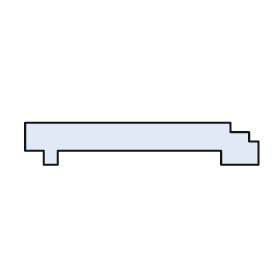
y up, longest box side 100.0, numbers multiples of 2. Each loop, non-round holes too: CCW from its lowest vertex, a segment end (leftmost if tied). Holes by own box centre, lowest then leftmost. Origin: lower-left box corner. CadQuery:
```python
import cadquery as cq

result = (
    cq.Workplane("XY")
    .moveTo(8.0, 0.0)
    .lineTo(14.0, 0.0)
    .lineTo(14.0, 6.0)
    .lineTo(84.0, 6.0)
    .lineTo(84.0, 0.0)
    .lineTo(100.0, 0.0)
    .lineTo(100.0, 10.0)
    .lineTo(96.0, 10.0)
    .lineTo(96.0, 14.0)
    .lineTo(88.0, 14.0)
    .lineTo(88.0, 18.0)
    .lineTo(0.0, 18.0)
    .lineTo(0.0, 6.0)
    .lineTo(8.0, 6.0)
    .close()
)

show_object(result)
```